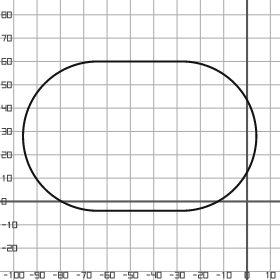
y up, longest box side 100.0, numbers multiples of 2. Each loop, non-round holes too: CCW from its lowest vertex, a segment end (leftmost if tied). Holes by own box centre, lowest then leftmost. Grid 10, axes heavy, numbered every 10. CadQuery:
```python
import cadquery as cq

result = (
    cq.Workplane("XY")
    .moveTo(-64.0, -4.0)
    .lineTo(-28.0, -4.0)
    .threePointArc((4.0, 28.0), (-28.0, 60.0))
    .lineTo(-64.0, 60.0)
    .threePointArc((-96.0, 28.0), (-64.0, -4.0))
    .close()
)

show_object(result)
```